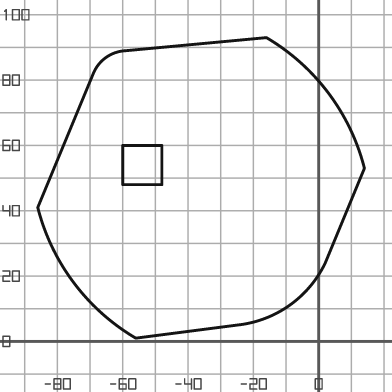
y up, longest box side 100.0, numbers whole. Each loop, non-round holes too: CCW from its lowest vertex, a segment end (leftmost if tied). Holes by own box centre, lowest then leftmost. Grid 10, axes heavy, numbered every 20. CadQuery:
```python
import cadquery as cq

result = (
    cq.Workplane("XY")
    .moveTo(-56.0, 1.0)
    .lineTo(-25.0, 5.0)
    .threePointArc((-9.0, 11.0), (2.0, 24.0))
    .lineTo(14.0, 53.0)
    .threePointArc((3.0, 76.0), (-16.0, 93.0))
    .lineTo(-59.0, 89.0)
    .threePointArc((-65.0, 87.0), (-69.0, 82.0))
    .lineTo(-86.0, 41.0)
    .threePointArc((-75.0, 18.0), (-56.0, 1.0))
    .close()
    .moveTo(-60.0, 48.0)
    .lineTo(-48.0, 48.0)
    .lineTo(-48.0, 60.0)
    .lineTo(-60.0, 60.0)
    .close()
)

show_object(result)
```